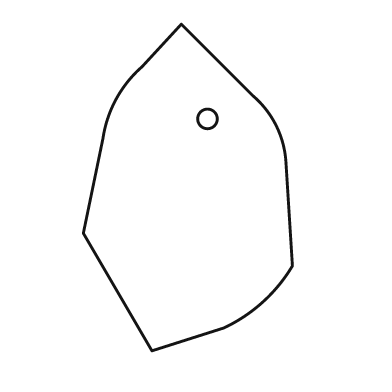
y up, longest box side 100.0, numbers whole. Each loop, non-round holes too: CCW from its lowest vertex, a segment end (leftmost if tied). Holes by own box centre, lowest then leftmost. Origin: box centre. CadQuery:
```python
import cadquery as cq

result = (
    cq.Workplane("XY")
    .moveTo(-11.0, -50.0)
    .lineTo(11.0, -43.0)
    .threePointArc((23.0, -35.0), (32.0, -24.0))
    .lineTo(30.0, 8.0)
    .threePointArc((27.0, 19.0), (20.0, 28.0))
    .lineTo(-2.0, 50.0)
    .lineTo(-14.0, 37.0)
    .threePointArc((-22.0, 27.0), (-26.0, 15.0))
    .lineTo(-32.0, -14.0)
    .close()
    .moveTo(6.0, 21.0)
    .circle(3.0)
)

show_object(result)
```